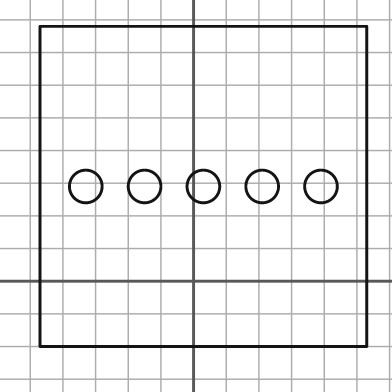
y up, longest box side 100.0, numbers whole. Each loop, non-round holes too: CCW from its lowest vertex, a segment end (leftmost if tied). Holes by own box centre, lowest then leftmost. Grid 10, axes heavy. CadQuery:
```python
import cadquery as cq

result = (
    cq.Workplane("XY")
    .moveTo(-47.0, -20.0)
    .lineTo(53.0, -20.0)
    .lineTo(53.0, 78.0)
    .lineTo(-47.0, 78.0)
    .close()
    .moveTo(-33.0, 29.0)
    .circle(5.0)
    .moveTo(-15.0, 29.0)
    .circle(5.0)
    .moveTo(3.0, 29.0)
    .circle(5.0)
    .moveTo(21.0, 29.0)
    .circle(5.0)
    .moveTo(39.0, 29.0)
    .circle(5.0)
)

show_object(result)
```